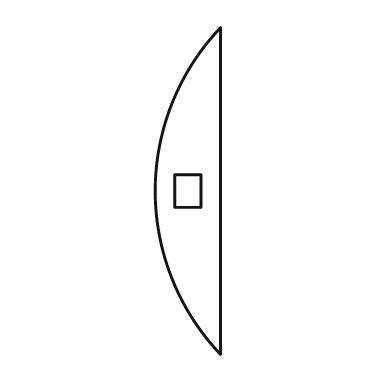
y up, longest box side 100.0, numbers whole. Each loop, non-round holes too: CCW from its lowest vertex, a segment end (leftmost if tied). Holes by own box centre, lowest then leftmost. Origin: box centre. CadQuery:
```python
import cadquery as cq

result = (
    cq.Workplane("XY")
    .moveTo(10.0, -50.0)
    .lineTo(10.0, 50.0)
    .threePointArc((-10.0, 0.0), (10.0, -50.0))
    .close()
    .moveTo(-4.0, -5.0)
    .lineTo(4.0, -5.0)
    .lineTo(4.0, 5.0)
    .lineTo(-4.0, 5.0)
    .close()
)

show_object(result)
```